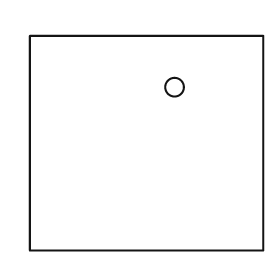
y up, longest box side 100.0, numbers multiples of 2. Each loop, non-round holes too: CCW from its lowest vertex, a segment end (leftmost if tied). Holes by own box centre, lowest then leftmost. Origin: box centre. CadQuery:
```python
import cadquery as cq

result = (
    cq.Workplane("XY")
    .moveTo(-50.0, -46.0)
    .lineTo(50.0, -46.0)
    .lineTo(50.0, 46.0)
    .lineTo(-50.0, 46.0)
    .close()
    .moveTo(12.0, 24.0)
    .circle(4.0)
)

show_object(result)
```